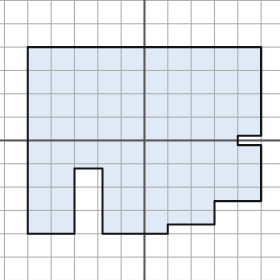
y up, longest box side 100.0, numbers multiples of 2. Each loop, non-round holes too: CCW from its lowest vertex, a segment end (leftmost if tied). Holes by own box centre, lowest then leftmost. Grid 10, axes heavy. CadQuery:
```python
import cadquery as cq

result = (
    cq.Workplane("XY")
    .moveTo(-50.0, -40.0)
    .lineTo(-30.0, -40.0)
    .lineTo(-30.0, -12.0)
    .lineTo(-18.0, -12.0)
    .lineTo(-18.0, -40.0)
    .lineTo(10.0, -40.0)
    .lineTo(10.0, -36.0)
    .lineTo(30.0, -36.0)
    .lineTo(30.0, -26.0)
    .lineTo(50.0, -26.0)
    .lineTo(50.0, -2.0)
    .lineTo(40.0, -2.0)
    .lineTo(40.0, 2.0)
    .lineTo(50.0, 2.0)
    .lineTo(50.0, 40.0)
    .lineTo(-50.0, 40.0)
    .close()
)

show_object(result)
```